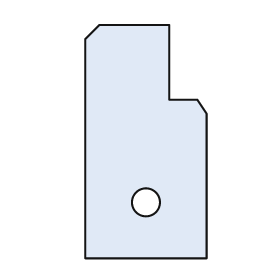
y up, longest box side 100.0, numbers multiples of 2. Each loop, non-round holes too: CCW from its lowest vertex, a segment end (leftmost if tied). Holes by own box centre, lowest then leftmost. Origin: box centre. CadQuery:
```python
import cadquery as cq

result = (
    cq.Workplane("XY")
    .moveTo(-26.0, -50.0)
    .lineTo(26.0, -50.0)
    .lineTo(26.0, 12.0)
    .lineTo(22.0, 18.0)
    .lineTo(10.0, 18.0)
    .lineTo(10.0, 50.0)
    .lineTo(-20.0, 50.0)
    .lineTo(-26.0, 44.0)
    .close()
    .moveTo(0.0, -26.0)
    .circle(6.0)
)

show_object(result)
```